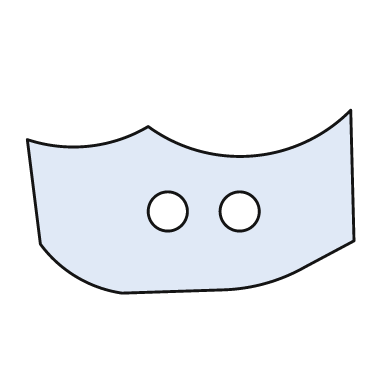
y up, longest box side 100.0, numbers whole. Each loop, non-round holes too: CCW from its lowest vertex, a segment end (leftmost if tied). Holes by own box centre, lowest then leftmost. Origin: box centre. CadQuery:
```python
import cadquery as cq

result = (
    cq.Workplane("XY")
    .moveTo(-21.0, -28.0)
    .lineTo(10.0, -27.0)
    .threePointArc((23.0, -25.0), (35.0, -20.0))
    .lineTo(50.0, -12.0)
    .lineTo(49.0, 28.0)
    .threePointArc((19.0, 14.0), (-13.0, 23.0))
    .threePointArc((-31.0, 17.0), (-50.0, 19.0))
    .lineTo(-46.0, -13.0)
    .threePointArc((-35.0, -23.0), (-21.0, -28.0))
    .close()
    .moveTo(-7.0, -3.0)
    .circle(6.0)
    .moveTo(15.0, -3.0)
    .circle(6.0)
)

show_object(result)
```